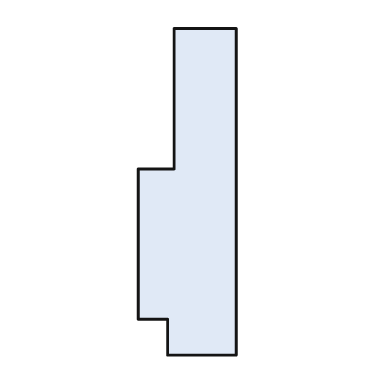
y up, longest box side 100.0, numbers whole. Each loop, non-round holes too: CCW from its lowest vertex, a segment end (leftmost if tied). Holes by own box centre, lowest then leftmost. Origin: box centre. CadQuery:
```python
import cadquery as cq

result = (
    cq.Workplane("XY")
    .moveTo(-6.0, -50.0)
    .lineTo(15.0, -50.0)
    .lineTo(15.0, 50.0)
    .lineTo(-4.0, 50.0)
    .lineTo(-4.0, 7.0)
    .lineTo(-15.0, 7.0)
    .lineTo(-15.0, -39.0)
    .lineTo(-6.0, -39.0)
    .close()
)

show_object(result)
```